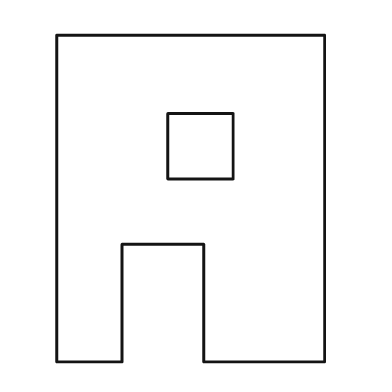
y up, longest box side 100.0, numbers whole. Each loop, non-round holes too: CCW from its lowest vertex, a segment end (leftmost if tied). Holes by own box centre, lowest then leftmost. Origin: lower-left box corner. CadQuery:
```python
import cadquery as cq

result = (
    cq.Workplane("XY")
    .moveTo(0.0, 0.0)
    .lineTo(20.0, 0.0)
    .lineTo(20.0, 36.0)
    .lineTo(45.0, 36.0)
    .lineTo(45.0, 0.0)
    .lineTo(82.0, 0.0)
    .lineTo(82.0, 100.0)
    .lineTo(0.0, 100.0)
    .close()
    .moveTo(34.0, 56.0)
    .lineTo(54.0, 56.0)
    .lineTo(54.0, 76.0)
    .lineTo(34.0, 76.0)
    .close()
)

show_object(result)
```